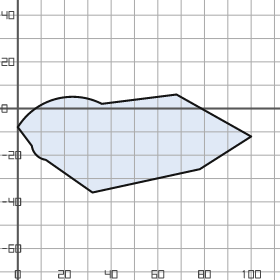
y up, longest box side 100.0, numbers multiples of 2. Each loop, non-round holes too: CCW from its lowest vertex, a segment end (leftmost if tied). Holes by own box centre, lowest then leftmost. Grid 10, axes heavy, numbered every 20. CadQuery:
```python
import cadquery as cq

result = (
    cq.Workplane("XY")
    .moveTo(32.0, -36.0)
    .lineTo(78.0, -26.0)
    .lineTo(100.0, -12.0)
    .lineTo(68.0, 6.0)
    .lineTo(36.0, 2.0)
    .threePointArc((16.0, 4.0), (0.0, -8.0))
    .lineTo(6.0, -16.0)
    .threePointArc((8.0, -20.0), (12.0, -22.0))
    .close()
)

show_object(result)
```